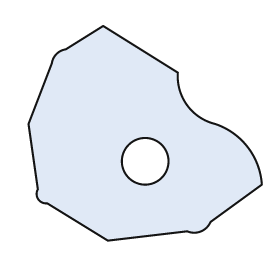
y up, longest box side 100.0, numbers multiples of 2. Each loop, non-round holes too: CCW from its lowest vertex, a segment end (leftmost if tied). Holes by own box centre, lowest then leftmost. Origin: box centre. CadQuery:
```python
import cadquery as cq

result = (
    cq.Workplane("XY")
    .moveTo(-16.0, -46.0)
    .lineTo(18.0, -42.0)
    .threePointArc((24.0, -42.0), (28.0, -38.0))
    .lineTo(50.0, -22.0)
    .threePointArc((44.0, -6.0), (30.0, 4.0))
    .threePointArc((18.0, 12.0), (14.0, 26.0))
    .lineTo(-18.0, 46.0)
    .lineTo(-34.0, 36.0)
    .threePointArc((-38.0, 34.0), (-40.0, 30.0))
    .lineTo(-50.0, 4.0)
    .lineTo(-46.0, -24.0)
    .threePointArc((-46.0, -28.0), (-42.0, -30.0))
    .close()
    .moveTo(0.0, -12.0)
    .circle(10.0)
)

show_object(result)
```